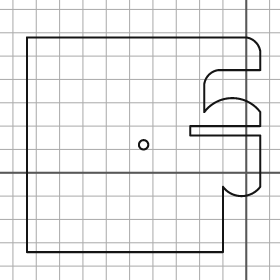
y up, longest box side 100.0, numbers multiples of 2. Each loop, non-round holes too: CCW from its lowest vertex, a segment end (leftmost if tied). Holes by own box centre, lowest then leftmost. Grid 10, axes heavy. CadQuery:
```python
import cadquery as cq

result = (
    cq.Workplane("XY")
    .moveTo(-94.0, -34.0)
    .lineTo(-10.0, -34.0)
    .lineTo(-10.0, -6.0)
    .threePointArc((-2.0, -10.0), (6.0, -6.0))
    .lineTo(6.0, 16.0)
    .lineTo(-24.0, 16.0)
    .lineTo(-24.0, 20.0)
    .lineTo(6.0, 20.0)
    .lineTo(6.0, 26.0)
    .threePointArc((-6.0, 32.0), (-18.0, 26.0))
    .lineTo(-18.0, 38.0)
    .threePointArc((-16.0, 42.0), (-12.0, 44.0))
    .lineTo(6.0, 44.0)
    .lineTo(6.0, 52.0)
    .threePointArc((4.0, 56.0), (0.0, 58.0))
    .lineTo(-94.0, 58.0)
    .close()
    .moveTo(-44.0, 12.0)
    .circle(2.0)
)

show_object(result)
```